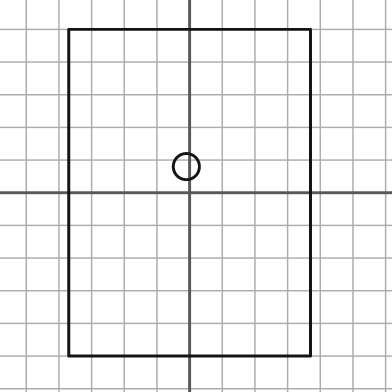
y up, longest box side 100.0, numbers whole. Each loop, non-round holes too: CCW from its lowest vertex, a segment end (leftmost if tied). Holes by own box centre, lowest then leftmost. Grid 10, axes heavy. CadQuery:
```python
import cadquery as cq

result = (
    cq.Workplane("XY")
    .moveTo(-37.0, -50.0)
    .lineTo(37.0, -50.0)
    .lineTo(37.0, 50.0)
    .lineTo(-37.0, 50.0)
    .close()
    .moveTo(-1.0, 8.0)
    .circle(4.0)
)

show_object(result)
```